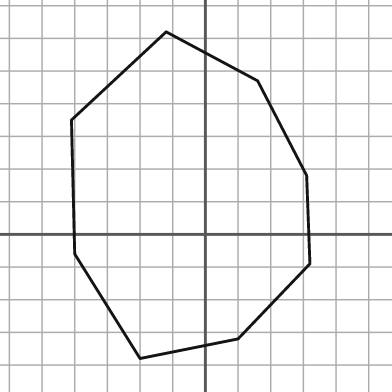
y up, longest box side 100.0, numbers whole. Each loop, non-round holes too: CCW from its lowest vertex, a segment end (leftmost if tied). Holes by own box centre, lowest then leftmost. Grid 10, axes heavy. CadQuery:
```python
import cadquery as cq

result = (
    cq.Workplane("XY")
    .moveTo(-20.0, -38.0)
    .lineTo(10.0, -32.0)
    .lineTo(32.0, -9.0)
    .lineTo(31.0, 18.0)
    .lineTo(16.0, 47.0)
    .lineTo(-12.0, 62.0)
    .lineTo(-41.0, 35.0)
    .lineTo(-40.0, -6.0)
    .close()
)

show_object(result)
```